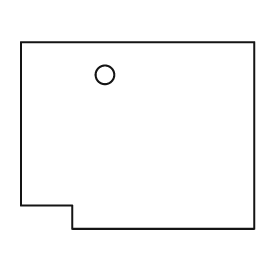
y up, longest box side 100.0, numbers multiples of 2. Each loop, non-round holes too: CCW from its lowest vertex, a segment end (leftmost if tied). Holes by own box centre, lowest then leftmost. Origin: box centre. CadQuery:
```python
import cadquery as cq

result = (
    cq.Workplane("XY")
    .moveTo(-28.0, -40.0)
    .lineTo(50.0, -40.0)
    .lineTo(50.0, 40.0)
    .lineTo(-50.0, 40.0)
    .lineTo(-50.0, -30.0)
    .lineTo(-28.0, -30.0)
    .close()
    .moveTo(-14.0, 26.0)
    .circle(4.0)
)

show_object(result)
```